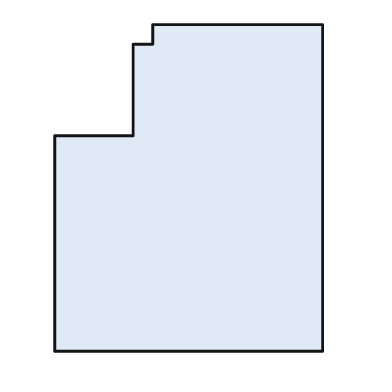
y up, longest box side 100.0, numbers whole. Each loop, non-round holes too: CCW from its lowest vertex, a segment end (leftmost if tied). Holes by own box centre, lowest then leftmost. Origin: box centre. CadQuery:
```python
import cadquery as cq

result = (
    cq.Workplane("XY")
    .moveTo(-41.0, -50.0)
    .lineTo(41.0, -50.0)
    .lineTo(41.0, 50.0)
    .lineTo(-11.0, 50.0)
    .lineTo(-11.0, 44.0)
    .lineTo(-17.0, 44.0)
    .lineTo(-17.0, 16.0)
    .lineTo(-41.0, 16.0)
    .close()
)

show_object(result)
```